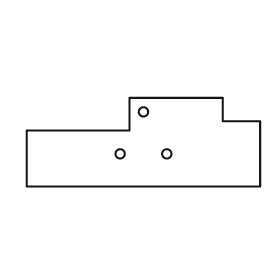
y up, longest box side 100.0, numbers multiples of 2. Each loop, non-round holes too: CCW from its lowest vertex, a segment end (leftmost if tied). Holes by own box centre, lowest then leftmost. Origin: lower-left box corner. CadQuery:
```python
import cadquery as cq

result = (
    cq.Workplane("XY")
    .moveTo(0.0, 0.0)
    .lineTo(100.0, 0.0)
    .lineTo(100.0, 28.0)
    .lineTo(84.0, 28.0)
    .lineTo(84.0, 38.0)
    .lineTo(44.0, 38.0)
    .lineTo(44.0, 24.0)
    .lineTo(0.0, 24.0)
    .close()
    .moveTo(40.0, 14.0)
    .circle(2.0)
    .moveTo(60.0, 14.0)
    .circle(2.0)
    .moveTo(50.0, 32.0)
    .circle(2.0)
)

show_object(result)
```